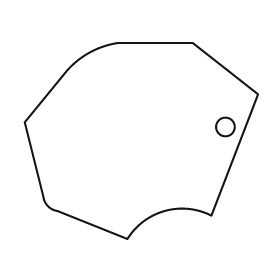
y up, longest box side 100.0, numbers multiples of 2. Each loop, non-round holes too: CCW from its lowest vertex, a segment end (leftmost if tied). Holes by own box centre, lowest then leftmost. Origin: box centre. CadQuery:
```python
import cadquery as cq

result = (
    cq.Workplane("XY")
    .moveTo(-6.0, -42.0)
    .threePointArc((10.0, -30.0), (30.0, -32.0))
    .lineTo(50.0, 20.0)
    .lineTo(22.0, 42.0)
    .lineTo(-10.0, 42.0)
    .threePointArc((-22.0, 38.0), (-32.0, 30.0))
    .lineTo(-50.0, 8.0)
    .lineTo(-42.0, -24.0)
    .threePointArc((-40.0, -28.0), (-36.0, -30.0))
    .close()
    .moveTo(36.0, 6.0)
    .circle(4.0)
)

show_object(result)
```